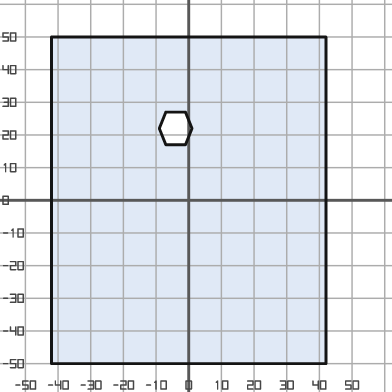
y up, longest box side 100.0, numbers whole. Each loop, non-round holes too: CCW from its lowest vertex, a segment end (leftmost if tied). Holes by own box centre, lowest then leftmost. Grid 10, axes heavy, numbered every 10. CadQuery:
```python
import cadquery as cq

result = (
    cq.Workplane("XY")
    .moveTo(-42.0, -50.0)
    .lineTo(42.0, -50.0)
    .lineTo(42.0, 50.0)
    .lineTo(-42.0, 50.0)
    .close()
    .moveTo(-7.0, 17.0)
    .lineTo(-1.0, 17.0)
    .lineTo(1.0, 22.0)
    .lineTo(-1.0, 27.0)
    .lineTo(-7.0, 27.0)
    .lineTo(-9.0, 22.0)
    .close()
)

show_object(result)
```